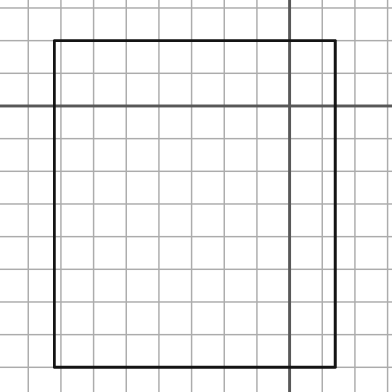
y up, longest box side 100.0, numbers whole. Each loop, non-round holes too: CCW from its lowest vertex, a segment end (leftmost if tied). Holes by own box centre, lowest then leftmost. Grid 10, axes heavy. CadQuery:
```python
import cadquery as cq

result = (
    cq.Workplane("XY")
    .moveTo(-72.0, -80.0)
    .lineTo(14.0, -80.0)
    .lineTo(14.0, 20.0)
    .lineTo(-72.0, 20.0)
    .close()
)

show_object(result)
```